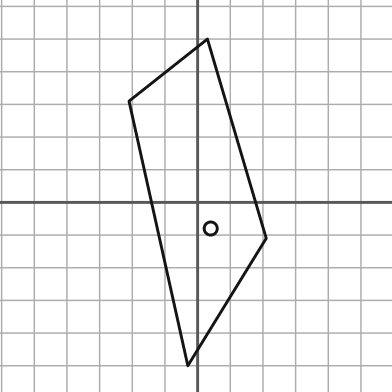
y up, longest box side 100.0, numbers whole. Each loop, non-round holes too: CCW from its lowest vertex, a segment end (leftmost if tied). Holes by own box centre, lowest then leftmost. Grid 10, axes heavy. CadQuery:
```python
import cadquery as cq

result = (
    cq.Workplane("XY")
    .moveTo(-3.0, -50.0)
    .lineTo(21.0, -11.0)
    .lineTo(3.0, 50.0)
    .lineTo(-21.0, 31.0)
    .close()
    .moveTo(4.0, -8.0)
    .circle(2.0)
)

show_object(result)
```